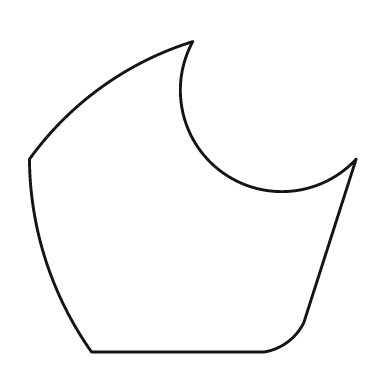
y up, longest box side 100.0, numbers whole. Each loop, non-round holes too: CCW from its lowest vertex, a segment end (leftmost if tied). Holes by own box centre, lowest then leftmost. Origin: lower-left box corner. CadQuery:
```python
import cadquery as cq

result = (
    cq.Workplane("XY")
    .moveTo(19.0, 0.0)
    .lineTo(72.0, 0.0)
    .threePointArc((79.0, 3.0), (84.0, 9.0))
    .lineTo(100.0, 59.0)
    .threePointArc((59.0, 55.0), (50.0, 95.0))
    .threePointArc((22.0, 81.0), (0.0, 59.0))
    .threePointArc((5.0, 28.0), (19.0, 0.0))
    .close()
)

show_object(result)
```